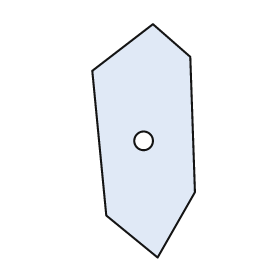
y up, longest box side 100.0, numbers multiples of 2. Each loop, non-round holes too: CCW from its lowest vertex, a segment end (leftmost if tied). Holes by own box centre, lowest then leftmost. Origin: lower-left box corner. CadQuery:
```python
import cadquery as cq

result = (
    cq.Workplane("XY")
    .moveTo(28.0, 0.0)
    .lineTo(44.0, 28.0)
    .lineTo(42.0, 86.0)
    .lineTo(26.0, 100.0)
    .lineTo(0.0, 80.0)
    .lineTo(6.0, 18.0)
    .close()
    .moveTo(22.0, 50.0)
    .circle(4.0)
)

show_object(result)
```